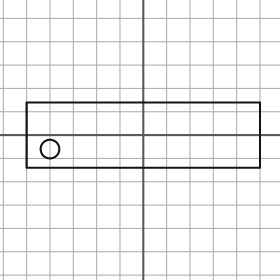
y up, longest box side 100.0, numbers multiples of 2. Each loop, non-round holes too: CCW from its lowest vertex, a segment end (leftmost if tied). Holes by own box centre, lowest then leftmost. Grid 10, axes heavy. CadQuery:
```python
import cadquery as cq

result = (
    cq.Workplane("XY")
    .moveTo(-50.0, -14.0)
    .lineTo(50.0, -14.0)
    .lineTo(50.0, 14.0)
    .lineTo(-50.0, 14.0)
    .close()
    .moveTo(-40.0, -6.0)
    .circle(4.0)
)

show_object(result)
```